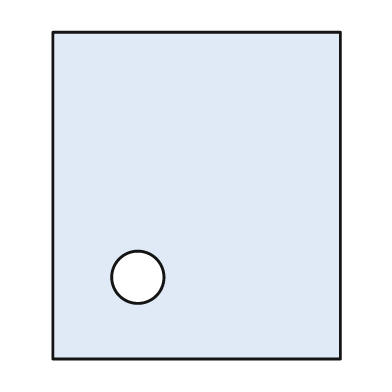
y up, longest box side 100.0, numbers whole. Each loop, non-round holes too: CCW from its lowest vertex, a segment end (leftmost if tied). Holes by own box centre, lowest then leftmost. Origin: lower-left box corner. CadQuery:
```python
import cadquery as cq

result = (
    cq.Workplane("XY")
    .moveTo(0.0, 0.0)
    .lineTo(88.0, 0.0)
    .lineTo(88.0, 100.0)
    .lineTo(0.0, 100.0)
    .close()
    .moveTo(26.0, 25.0)
    .circle(8.0)
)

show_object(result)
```